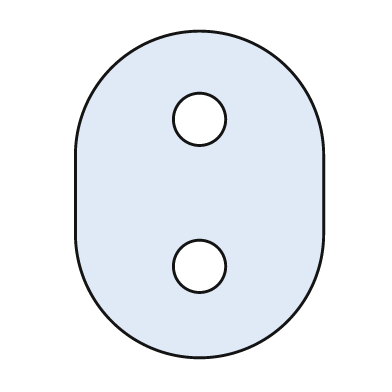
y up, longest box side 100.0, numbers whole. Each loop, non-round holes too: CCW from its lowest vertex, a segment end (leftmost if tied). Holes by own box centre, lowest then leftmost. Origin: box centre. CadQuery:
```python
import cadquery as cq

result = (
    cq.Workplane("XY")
    .moveTo(-38.0, -12.0)
    .threePointArc((0.0, -50.0), (38.0, -12.0))
    .lineTo(38.0, 12.0)
    .threePointArc((0.0, 50.0), (-38.0, 12.0))
    .close()
    .moveTo(0.0, -22.0)
    .circle(8.0)
    .moveTo(0.0, 23.0)
    .circle(8.0)
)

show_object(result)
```